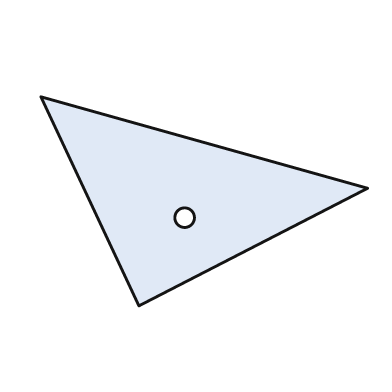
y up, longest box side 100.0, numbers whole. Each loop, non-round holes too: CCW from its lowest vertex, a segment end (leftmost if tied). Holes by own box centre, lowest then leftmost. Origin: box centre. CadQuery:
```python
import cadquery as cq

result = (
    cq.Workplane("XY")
    .moveTo(-20.0, -32.0)
    .lineTo(50.0, 4.0)
    .lineTo(-50.0, 32.0)
    .close()
    .moveTo(-6.0, -5.0)
    .circle(3.0)
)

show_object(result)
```